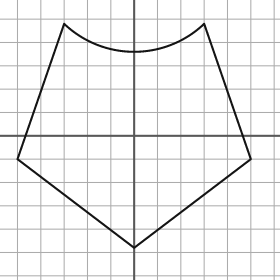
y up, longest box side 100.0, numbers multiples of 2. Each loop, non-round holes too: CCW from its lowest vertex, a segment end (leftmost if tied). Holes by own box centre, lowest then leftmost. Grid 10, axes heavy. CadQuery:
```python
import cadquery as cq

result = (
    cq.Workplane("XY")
    .moveTo(0.0, -48.0)
    .lineTo(50.0, -10.0)
    .lineTo(30.0, 48.0)
    .threePointArc((0.0, 36.0), (-30.0, 48.0))
    .lineTo(-50.0, -10.0)
    .close()
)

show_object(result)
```